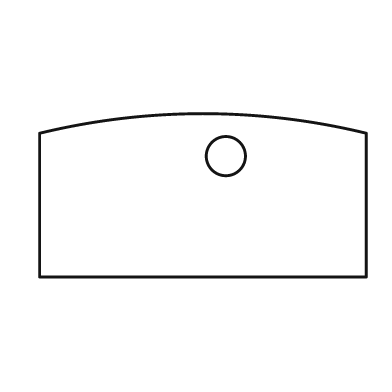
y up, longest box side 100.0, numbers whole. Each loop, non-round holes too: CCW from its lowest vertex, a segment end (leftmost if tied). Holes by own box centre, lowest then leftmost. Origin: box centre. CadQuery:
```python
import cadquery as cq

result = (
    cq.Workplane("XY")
    .moveTo(-50.0, -25.0)
    .lineTo(50.0, -25.0)
    .lineTo(50.0, 19.0)
    .threePointArc((0.0, 25.0), (-50.0, 19.0))
    .close()
    .moveTo(7.0, 12.0)
    .circle(6.0)
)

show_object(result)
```